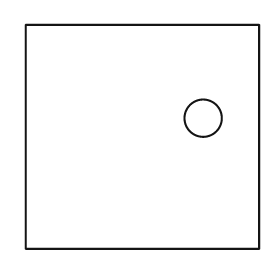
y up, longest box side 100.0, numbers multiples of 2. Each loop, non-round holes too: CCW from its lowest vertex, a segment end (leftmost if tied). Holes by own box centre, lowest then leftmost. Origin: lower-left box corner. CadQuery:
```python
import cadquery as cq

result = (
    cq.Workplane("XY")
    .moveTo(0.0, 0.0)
    .lineTo(100.0, 0.0)
    .lineTo(100.0, 96.0)
    .lineTo(0.0, 96.0)
    .close()
    .moveTo(76.0, 56.0)
    .circle(8.0)
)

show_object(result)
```